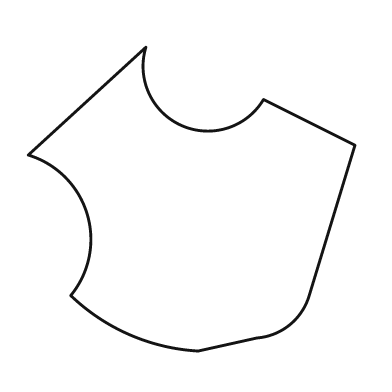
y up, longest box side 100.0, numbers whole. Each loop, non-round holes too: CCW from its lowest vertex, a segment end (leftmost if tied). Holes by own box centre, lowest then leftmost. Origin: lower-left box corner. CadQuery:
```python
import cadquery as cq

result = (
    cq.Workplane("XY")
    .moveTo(52.0, 0.0)
    .lineTo(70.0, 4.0)
    .threePointArc((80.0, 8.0), (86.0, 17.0))
    .lineTo(100.0, 63.0)
    .lineTo(72.0, 77.0)
    .threePointArc((47.0, 69.0), (36.0, 93.0))
    .lineTo(0.0, 60.0)
    .threePointArc((18.0, 42.0), (13.0, 17.0))
    .threePointArc((31.0, 5.0), (52.0, 0.0))
    .close()
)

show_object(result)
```